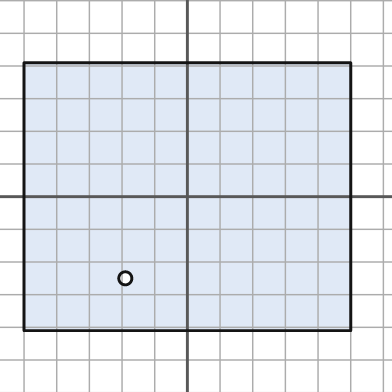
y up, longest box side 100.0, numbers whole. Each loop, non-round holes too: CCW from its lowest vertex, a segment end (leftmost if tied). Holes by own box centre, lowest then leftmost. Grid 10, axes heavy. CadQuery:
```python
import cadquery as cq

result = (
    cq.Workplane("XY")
    .moveTo(-50.0, -41.0)
    .lineTo(50.0, -41.0)
    .lineTo(50.0, 41.0)
    .lineTo(-50.0, 41.0)
    .close()
    .moveTo(-19.0, -25.0)
    .circle(2.0)
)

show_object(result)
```